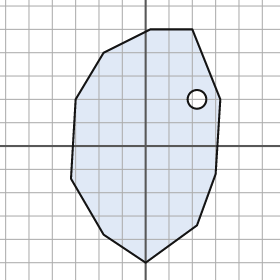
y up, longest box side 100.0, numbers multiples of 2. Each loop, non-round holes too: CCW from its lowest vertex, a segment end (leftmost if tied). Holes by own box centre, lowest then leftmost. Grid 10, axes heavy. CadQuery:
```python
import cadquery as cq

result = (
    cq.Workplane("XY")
    .moveTo(0.0, -50.0)
    .lineTo(22.0, -34.0)
    .lineTo(30.0, -12.0)
    .lineTo(32.0, 20.0)
    .lineTo(20.0, 50.0)
    .lineTo(2.0, 50.0)
    .lineTo(-18.0, 40.0)
    .lineTo(-30.0, 20.0)
    .lineTo(-32.0, -14.0)
    .lineTo(-18.0, -38.0)
    .close()
    .moveTo(22.0, 20.0)
    .circle(4.0)
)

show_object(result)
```